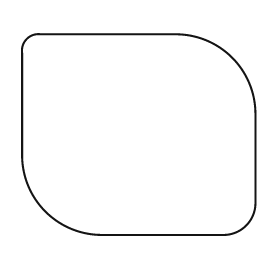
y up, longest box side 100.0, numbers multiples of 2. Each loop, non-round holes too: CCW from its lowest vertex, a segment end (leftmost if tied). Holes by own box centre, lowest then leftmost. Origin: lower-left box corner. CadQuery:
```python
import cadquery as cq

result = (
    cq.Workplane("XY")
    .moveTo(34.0, 0.0)
    .lineTo(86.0, 0.0)
    .threePointArc((96.0, 4.0), (100.0, 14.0))
    .lineTo(100.0, 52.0)
    .threePointArc((90.0, 76.0), (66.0, 86.0))
    .lineTo(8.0, 86.0)
    .threePointArc((2.0, 84.0), (0.0, 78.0))
    .lineTo(0.0, 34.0)
    .threePointArc((10.0, 10.0), (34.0, 0.0))
    .close()
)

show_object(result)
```